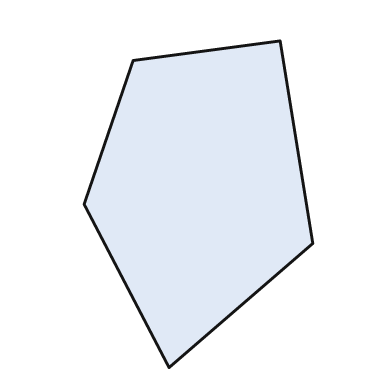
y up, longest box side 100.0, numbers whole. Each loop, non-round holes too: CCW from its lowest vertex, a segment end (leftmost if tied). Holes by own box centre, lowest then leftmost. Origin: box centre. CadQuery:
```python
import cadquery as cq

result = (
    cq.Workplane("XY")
    .moveTo(-9.0, -50.0)
    .lineTo(35.0, -12.0)
    .lineTo(25.0, 50.0)
    .lineTo(-20.0, 44.0)
    .lineTo(-35.0, 0.0)
    .close()
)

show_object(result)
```